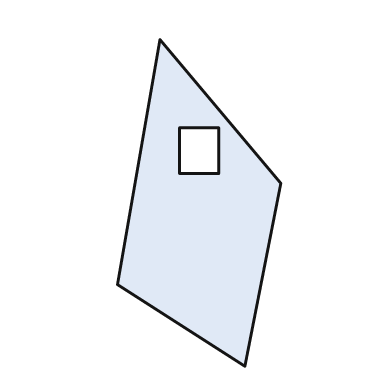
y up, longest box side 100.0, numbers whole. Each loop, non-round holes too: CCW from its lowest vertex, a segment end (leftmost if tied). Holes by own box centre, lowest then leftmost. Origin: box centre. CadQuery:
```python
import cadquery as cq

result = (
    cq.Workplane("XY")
    .moveTo(14.0, -50.0)
    .lineTo(25.0, 6.0)
    .lineTo(-12.0, 50.0)
    .lineTo(-25.0, -25.0)
    .close()
    .moveTo(-6.0, 9.0)
    .lineTo(6.0, 9.0)
    .lineTo(6.0, 23.0)
    .lineTo(-6.0, 23.0)
    .close()
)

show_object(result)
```